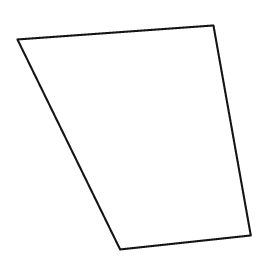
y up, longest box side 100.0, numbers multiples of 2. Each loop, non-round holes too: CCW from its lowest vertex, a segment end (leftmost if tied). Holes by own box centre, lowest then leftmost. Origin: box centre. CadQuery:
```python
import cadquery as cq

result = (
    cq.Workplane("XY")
    .moveTo(-6.0, -48.0)
    .lineTo(50.0, -42.0)
    .lineTo(34.0, 48.0)
    .lineTo(-50.0, 42.0)
    .close()
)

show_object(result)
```